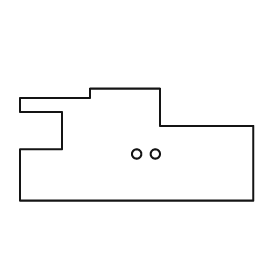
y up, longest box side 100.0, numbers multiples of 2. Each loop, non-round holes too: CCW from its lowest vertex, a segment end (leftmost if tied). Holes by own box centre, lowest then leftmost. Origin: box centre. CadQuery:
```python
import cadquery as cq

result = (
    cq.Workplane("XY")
    .moveTo(-50.0, -24.0)
    .lineTo(50.0, -24.0)
    .lineTo(50.0, 8.0)
    .lineTo(10.0, 8.0)
    .lineTo(10.0, 24.0)
    .lineTo(-20.0, 24.0)
    .lineTo(-20.0, 20.0)
    .lineTo(-50.0, 20.0)
    .lineTo(-50.0, 14.0)
    .lineTo(-32.0, 14.0)
    .lineTo(-32.0, -2.0)
    .lineTo(-50.0, -2.0)
    .close()
    .moveTo(0.0, -4.0)
    .circle(2.0)
    .moveTo(8.0, -4.0)
    .circle(2.0)
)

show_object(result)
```